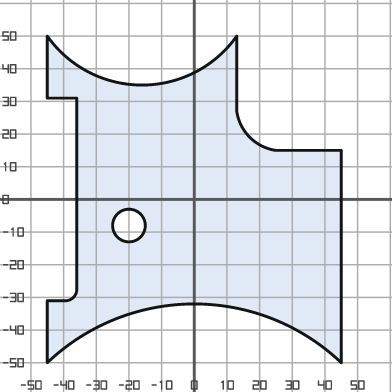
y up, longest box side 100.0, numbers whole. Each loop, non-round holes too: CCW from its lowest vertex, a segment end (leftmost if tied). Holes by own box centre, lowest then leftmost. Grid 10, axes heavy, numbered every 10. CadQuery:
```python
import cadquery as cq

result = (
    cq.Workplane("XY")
    .moveTo(-45.0, -50.0)
    .threePointArc((0.0, -32.0), (45.0, -50.0))
    .lineTo(45.0, 15.0)
    .lineTo(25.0, 15.0)
    .threePointArc((17.0, 19.0), (13.0, 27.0))
    .lineTo(13.0, 50.0)
    .threePointArc((-16.0, 35.0), (-45.0, 50.0))
    .lineTo(-45.0, 31.0)
    .lineTo(-36.0, 31.0)
    .lineTo(-36.0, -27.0)
    .threePointArc((-37.0, -30.0), (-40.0, -31.0))
    .lineTo(-45.0, -31.0)
    .close()
    .moveTo(-20.0, -8.0)
    .circle(5.0)
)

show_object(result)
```